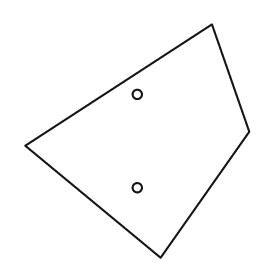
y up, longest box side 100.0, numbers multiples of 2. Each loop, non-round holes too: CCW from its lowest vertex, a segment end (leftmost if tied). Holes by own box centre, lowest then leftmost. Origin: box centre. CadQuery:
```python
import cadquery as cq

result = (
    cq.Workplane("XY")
    .moveTo(10.0, -50.0)
    .lineTo(48.0, 4.0)
    .lineTo(32.0, 50.0)
    .lineTo(-48.0, -2.0)
    .close()
    .moveTo(0.0, -20.0)
    .circle(2.0)
    .moveTo(0.0, 20.0)
    .circle(2.0)
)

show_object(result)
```